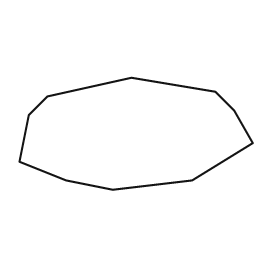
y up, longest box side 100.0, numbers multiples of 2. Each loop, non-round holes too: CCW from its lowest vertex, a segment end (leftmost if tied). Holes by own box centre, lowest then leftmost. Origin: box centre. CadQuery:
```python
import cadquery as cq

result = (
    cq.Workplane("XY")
    .moveTo(-10.0, -24.0)
    .lineTo(24.0, -20.0)
    .lineTo(50.0, -4.0)
    .lineTo(42.0, 10.0)
    .lineTo(34.0, 18.0)
    .lineTo(-2.0, 24.0)
    .lineTo(-38.0, 16.0)
    .lineTo(-46.0, 8.0)
    .lineTo(-50.0, -12.0)
    .lineTo(-30.0, -20.0)
    .close()
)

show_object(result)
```